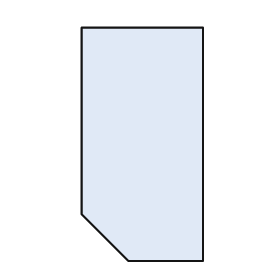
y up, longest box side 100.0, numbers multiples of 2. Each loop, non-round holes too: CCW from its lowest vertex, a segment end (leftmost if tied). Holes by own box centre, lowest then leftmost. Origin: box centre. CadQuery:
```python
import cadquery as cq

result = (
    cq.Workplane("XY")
    .moveTo(-6.0, -50.0)
    .lineTo(26.0, -50.0)
    .lineTo(26.0, 50.0)
    .lineTo(-26.0, 50.0)
    .lineTo(-26.0, -30.0)
    .close()
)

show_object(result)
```